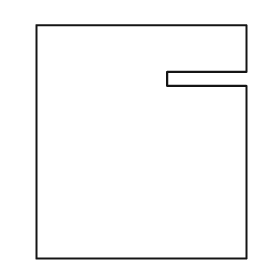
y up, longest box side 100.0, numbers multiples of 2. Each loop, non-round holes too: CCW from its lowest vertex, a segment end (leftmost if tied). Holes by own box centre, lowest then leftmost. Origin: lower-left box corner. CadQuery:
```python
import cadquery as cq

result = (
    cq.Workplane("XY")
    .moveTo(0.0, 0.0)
    .lineTo(90.0, 0.0)
    .lineTo(90.0, 74.0)
    .lineTo(56.0, 74.0)
    .lineTo(56.0, 80.0)
    .lineTo(90.0, 80.0)
    .lineTo(90.0, 100.0)
    .lineTo(0.0, 100.0)
    .close()
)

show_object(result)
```